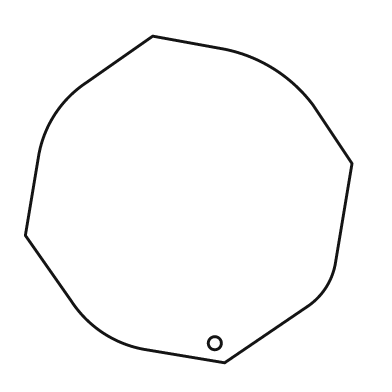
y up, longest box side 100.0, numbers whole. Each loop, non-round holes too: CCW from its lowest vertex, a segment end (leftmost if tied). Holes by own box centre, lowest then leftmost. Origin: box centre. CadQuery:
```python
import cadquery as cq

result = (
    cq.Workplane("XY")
    .moveTo(11.0, -50.0)
    .lineTo(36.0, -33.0)
    .threePointArc((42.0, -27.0), (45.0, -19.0))
    .lineTo(50.0, 11.0)
    .lineTo(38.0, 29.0)
    .threePointArc((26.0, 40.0), (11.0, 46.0))
    .lineTo(-11.0, 50.0)
    .lineTo(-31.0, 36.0)
    .threePointArc((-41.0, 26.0), (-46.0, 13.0))
    .lineTo(-50.0, -11.0)
    .lineTo(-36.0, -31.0)
    .threePointArc((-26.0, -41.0), (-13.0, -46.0))
    .close()
    .moveTo(8.0, -44.0)
    .circle(2.0)
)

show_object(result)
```